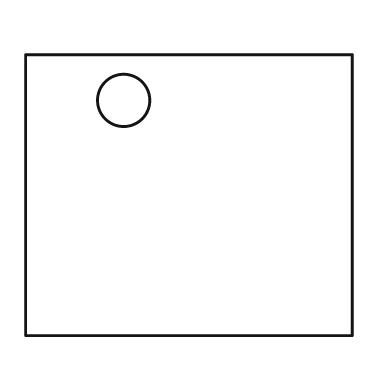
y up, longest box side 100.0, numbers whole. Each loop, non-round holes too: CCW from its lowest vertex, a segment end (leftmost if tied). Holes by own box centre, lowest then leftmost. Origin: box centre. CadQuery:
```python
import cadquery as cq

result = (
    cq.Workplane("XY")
    .moveTo(-50.0, -43.0)
    .lineTo(50.0, -43.0)
    .lineTo(50.0, 43.0)
    .lineTo(-50.0, 43.0)
    .close()
    .moveTo(-20.0, 29.0)
    .circle(8.0)
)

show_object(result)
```